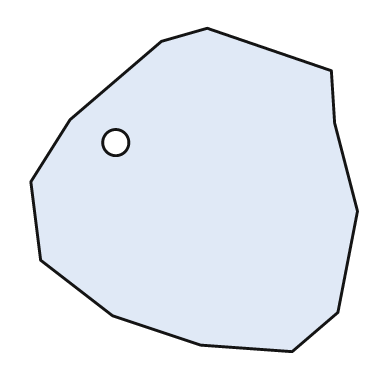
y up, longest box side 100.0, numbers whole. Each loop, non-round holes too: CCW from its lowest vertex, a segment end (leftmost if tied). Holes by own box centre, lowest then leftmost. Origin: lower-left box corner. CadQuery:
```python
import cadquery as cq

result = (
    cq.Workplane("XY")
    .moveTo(80.0, 0.0)
    .lineTo(94.0, 12.0)
    .lineTo(100.0, 43.0)
    .lineTo(93.0, 70.0)
    .lineTo(92.0, 86.0)
    .lineTo(54.0, 99.0)
    .lineTo(40.0, 95.0)
    .lineTo(12.0, 71.0)
    .lineTo(0.0, 52.0)
    .lineTo(3.0, 28.0)
    .lineTo(25.0, 11.0)
    .lineTo(52.0, 2.0)
    .close()
    .moveTo(26.0, 64.0)
    .circle(4.0)
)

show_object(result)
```